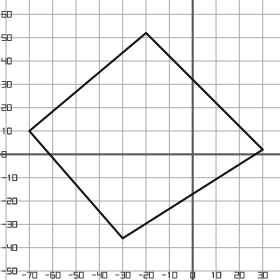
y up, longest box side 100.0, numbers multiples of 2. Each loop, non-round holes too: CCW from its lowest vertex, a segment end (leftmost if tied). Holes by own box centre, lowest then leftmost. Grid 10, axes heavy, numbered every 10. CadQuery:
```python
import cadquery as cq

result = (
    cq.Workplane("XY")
    .moveTo(-30.0, -36.0)
    .lineTo(30.0, 2.0)
    .lineTo(-20.0, 52.0)
    .lineTo(-70.0, 10.0)
    .close()
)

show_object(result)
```